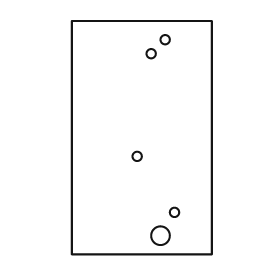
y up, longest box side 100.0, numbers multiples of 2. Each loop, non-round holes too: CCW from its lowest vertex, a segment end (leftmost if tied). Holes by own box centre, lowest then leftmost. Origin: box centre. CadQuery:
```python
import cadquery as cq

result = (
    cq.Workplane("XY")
    .moveTo(-30.0, -50.0)
    .lineTo(30.0, -50.0)
    .lineTo(30.0, 50.0)
    .lineTo(-30.0, 50.0)
    .close()
    .moveTo(8.0, -42.0)
    .circle(4.0)
    .moveTo(14.0, -32.0)
    .circle(2.0)
    .moveTo(-2.0, -8.0)
    .circle(2.0)
    .moveTo(4.0, 36.0)
    .circle(2.0)
    .moveTo(10.0, 42.0)
    .circle(2.0)
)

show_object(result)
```